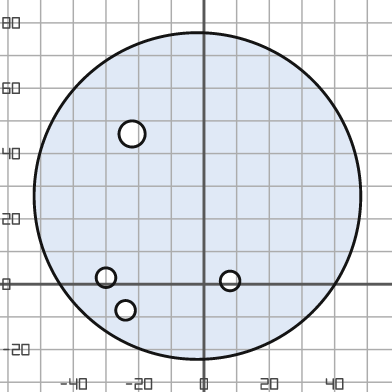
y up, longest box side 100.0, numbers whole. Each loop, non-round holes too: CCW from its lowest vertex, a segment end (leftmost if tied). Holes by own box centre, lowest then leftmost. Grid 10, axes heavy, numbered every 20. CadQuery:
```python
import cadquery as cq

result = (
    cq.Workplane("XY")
    .moveTo(-2.0, 27.0)
    .circle(50.0)
    .moveTo(-24.0, -8.0)
    .circle(3.0)
    .moveTo(8.0, 1.0)
    .circle(3.0)
    .moveTo(-30.0, 2.0)
    .circle(3.0)
    .moveTo(-22.0, 46.0)
    .circle(4.0)
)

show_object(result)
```